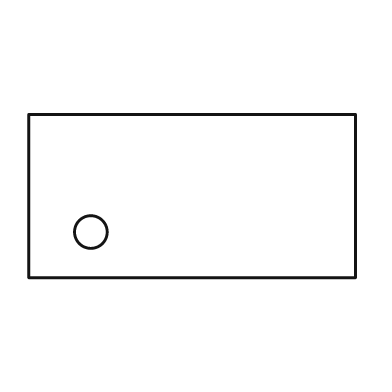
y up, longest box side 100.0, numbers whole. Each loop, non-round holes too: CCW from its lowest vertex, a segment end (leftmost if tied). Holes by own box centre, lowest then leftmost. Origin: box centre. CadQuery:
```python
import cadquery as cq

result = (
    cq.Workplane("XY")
    .moveTo(-50.0, -25.0)
    .lineTo(50.0, -25.0)
    .lineTo(50.0, 25.0)
    .lineTo(-50.0, 25.0)
    .close()
    .moveTo(-31.0, -11.0)
    .circle(5.0)
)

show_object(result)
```